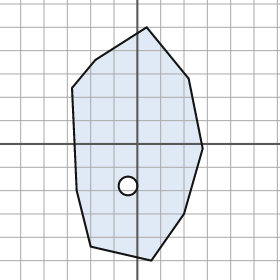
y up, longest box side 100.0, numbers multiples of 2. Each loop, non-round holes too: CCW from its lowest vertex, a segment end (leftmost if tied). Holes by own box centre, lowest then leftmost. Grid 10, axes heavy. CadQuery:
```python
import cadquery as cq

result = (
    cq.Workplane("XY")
    .moveTo(6.0, -50.0)
    .lineTo(20.0, -30.0)
    .lineTo(28.0, -2.0)
    .lineTo(22.0, 28.0)
    .lineTo(4.0, 50.0)
    .lineTo(-18.0, 36.0)
    .lineTo(-28.0, 24.0)
    .lineTo(-26.0, -20.0)
    .lineTo(-20.0, -44.0)
    .close()
    .moveTo(-4.0, -18.0)
    .circle(4.0)
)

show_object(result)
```